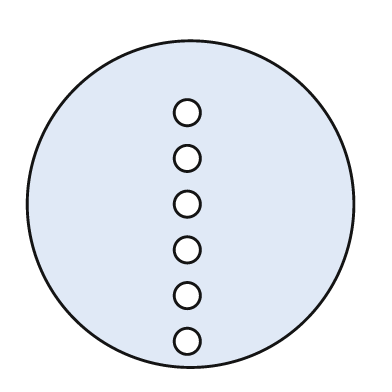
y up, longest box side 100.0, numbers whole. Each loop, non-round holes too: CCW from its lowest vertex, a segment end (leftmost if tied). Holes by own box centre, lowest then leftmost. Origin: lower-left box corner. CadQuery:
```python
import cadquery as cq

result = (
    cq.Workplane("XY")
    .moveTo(50.0, 50.0)
    .circle(50.0)
    .moveTo(49.0, 8.0)
    .circle(4.0)
    .moveTo(49.0, 22.0)
    .circle(4.0)
    .moveTo(49.0, 36.0)
    .circle(4.0)
    .moveTo(49.0, 50.0)
    .circle(4.0)
    .moveTo(49.0, 64.0)
    .circle(4.0)
    .moveTo(49.0, 78.0)
    .circle(4.0)
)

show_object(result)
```